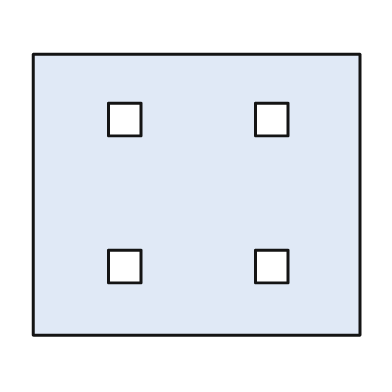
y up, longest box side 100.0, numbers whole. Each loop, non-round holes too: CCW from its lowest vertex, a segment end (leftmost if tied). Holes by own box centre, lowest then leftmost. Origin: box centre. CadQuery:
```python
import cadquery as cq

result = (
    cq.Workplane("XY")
    .moveTo(-50.0, -43.0)
    .lineTo(50.0, -43.0)
    .lineTo(50.0, 43.0)
    .lineTo(-50.0, 43.0)
    .close()
    .moveTo(-27.0, -27.0)
    .lineTo(-17.0, -27.0)
    .lineTo(-17.0, -17.0)
    .lineTo(-27.0, -17.0)
    .close()
    .moveTo(18.0, -27.0)
    .lineTo(28.0, -27.0)
    .lineTo(28.0, -17.0)
    .lineTo(18.0, -17.0)
    .close()
    .moveTo(-27.0, 18.0)
    .lineTo(-17.0, 18.0)
    .lineTo(-17.0, 28.0)
    .lineTo(-27.0, 28.0)
    .close()
    .moveTo(18.0, 18.0)
    .lineTo(28.0, 18.0)
    .lineTo(28.0, 28.0)
    .lineTo(18.0, 28.0)
    .close()
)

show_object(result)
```